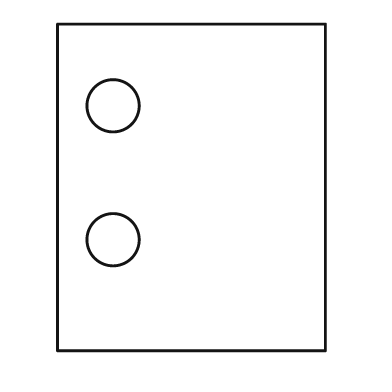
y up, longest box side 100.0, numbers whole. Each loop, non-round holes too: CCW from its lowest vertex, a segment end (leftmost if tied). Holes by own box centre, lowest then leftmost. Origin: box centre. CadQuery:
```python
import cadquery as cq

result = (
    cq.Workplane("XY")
    .moveTo(-41.0, -50.0)
    .lineTo(41.0, -50.0)
    .lineTo(41.0, 50.0)
    .lineTo(-41.0, 50.0)
    .close()
    .moveTo(-24.0, -16.0)
    .circle(8.0)
    .moveTo(-24.0, 25.0)
    .circle(8.0)
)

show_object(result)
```